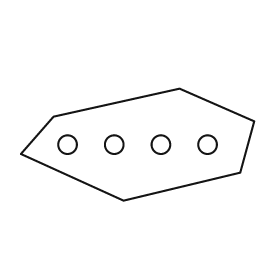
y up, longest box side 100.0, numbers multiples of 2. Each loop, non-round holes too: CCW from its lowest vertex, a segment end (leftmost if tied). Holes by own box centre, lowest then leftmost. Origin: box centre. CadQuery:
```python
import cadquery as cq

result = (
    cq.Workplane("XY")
    .moveTo(-6.0, -24.0)
    .lineTo(44.0, -12.0)
    .lineTo(50.0, 10.0)
    .lineTo(18.0, 24.0)
    .lineTo(-36.0, 12.0)
    .lineTo(-50.0, -4.0)
    .close()
    .moveTo(-30.0, 0.0)
    .circle(4.0)
    .moveTo(-10.0, 0.0)
    .circle(4.0)
    .moveTo(10.0, 0.0)
    .circle(4.0)
    .moveTo(30.0, 0.0)
    .circle(4.0)
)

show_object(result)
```